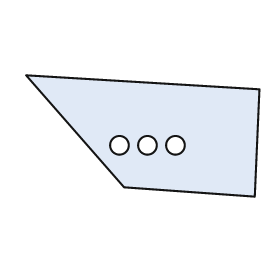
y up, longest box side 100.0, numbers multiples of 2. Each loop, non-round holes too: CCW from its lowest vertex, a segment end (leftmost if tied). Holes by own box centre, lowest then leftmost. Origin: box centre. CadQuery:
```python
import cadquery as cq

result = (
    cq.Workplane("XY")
    .moveTo(48.0, -26.0)
    .lineTo(50.0, 20.0)
    .lineTo(-50.0, 26.0)
    .lineTo(-8.0, -22.0)
    .close()
    .moveTo(-10.0, -4.0)
    .circle(4.0)
    .moveTo(2.0, -4.0)
    .circle(4.0)
    .moveTo(14.0, -4.0)
    .circle(4.0)
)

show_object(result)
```